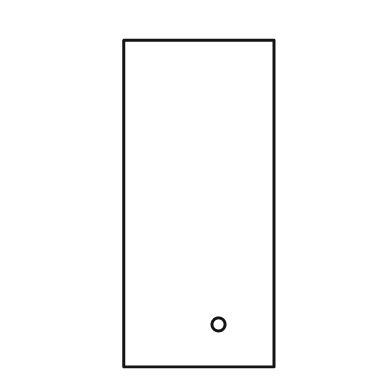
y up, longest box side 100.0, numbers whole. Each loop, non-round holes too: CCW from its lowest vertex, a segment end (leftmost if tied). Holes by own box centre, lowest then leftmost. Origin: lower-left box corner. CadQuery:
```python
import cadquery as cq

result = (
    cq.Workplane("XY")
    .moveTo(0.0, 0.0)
    .lineTo(46.0, 0.0)
    .lineTo(46.0, 100.0)
    .lineTo(0.0, 100.0)
    .close()
    .moveTo(29.0, 13.0)
    .circle(2.0)
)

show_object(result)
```